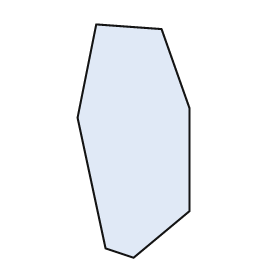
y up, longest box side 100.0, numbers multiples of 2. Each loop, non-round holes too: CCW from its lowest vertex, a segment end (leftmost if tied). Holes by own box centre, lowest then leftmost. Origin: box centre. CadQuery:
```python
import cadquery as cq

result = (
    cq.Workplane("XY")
    .moveTo(0.0, -50.0)
    .lineTo(24.0, -30.0)
    .lineTo(24.0, 14.0)
    .lineTo(12.0, 48.0)
    .lineTo(-16.0, 50.0)
    .lineTo(-24.0, 10.0)
    .lineTo(-12.0, -46.0)
    .close()
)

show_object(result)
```